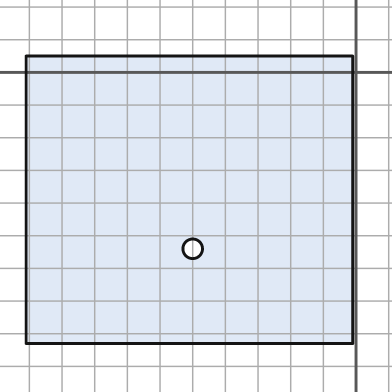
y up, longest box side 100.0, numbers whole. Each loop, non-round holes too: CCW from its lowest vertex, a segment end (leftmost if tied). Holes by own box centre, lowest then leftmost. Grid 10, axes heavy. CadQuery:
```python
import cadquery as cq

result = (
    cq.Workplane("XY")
    .moveTo(-101.0, -83.0)
    .lineTo(-1.0, -83.0)
    .lineTo(-1.0, 5.0)
    .lineTo(-101.0, 5.0)
    .close()
    .moveTo(-50.0, -54.0)
    .circle(3.0)
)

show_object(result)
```